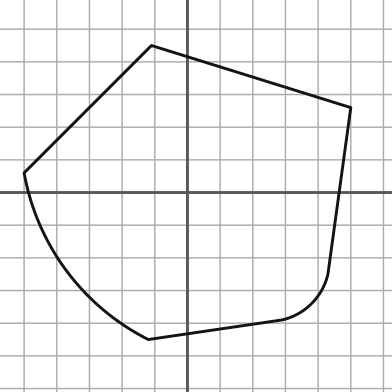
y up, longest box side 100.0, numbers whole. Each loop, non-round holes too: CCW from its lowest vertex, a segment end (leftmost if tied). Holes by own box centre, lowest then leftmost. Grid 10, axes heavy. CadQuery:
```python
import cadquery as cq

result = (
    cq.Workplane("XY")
    .moveTo(-12.0, -45.0)
    .lineTo(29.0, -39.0)
    .threePointArc((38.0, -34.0), (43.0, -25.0))
    .lineTo(50.0, 26.0)
    .lineTo(-11.0, 45.0)
    .lineTo(-50.0, 6.0)
    .threePointArc((-37.0, -24.0), (-12.0, -45.0))
    .close()
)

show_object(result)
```